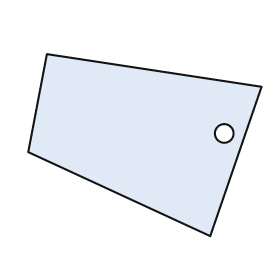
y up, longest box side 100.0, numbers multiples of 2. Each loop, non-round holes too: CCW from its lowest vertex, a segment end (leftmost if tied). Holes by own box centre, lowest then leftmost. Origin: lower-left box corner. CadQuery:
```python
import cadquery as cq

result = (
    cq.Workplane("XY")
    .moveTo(78.0, 0.0)
    .lineTo(100.0, 64.0)
    .lineTo(8.0, 78.0)
    .lineTo(0.0, 36.0)
    .close()
    .moveTo(84.0, 44.0)
    .circle(4.0)
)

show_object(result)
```